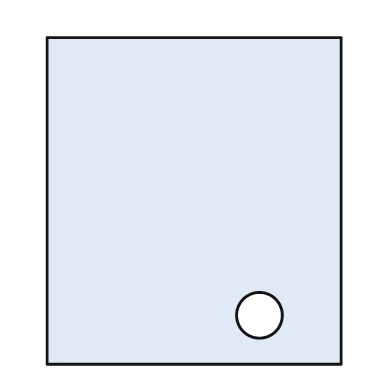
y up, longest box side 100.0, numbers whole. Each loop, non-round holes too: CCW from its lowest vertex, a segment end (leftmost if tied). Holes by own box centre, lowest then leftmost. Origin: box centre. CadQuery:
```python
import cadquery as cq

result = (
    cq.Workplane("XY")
    .moveTo(-45.0, -50.0)
    .lineTo(45.0, -50.0)
    .lineTo(45.0, 50.0)
    .lineTo(-45.0, 50.0)
    .close()
    .moveTo(20.0, -35.0)
    .circle(7.0)
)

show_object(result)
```